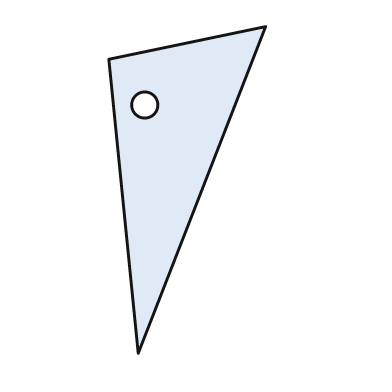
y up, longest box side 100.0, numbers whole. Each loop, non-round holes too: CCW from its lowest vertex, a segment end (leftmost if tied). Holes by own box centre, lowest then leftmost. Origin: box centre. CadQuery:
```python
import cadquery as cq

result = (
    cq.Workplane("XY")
    .moveTo(-15.0, -50.0)
    .lineTo(24.0, 50.0)
    .lineTo(-24.0, 40.0)
    .close()
    .moveTo(-13.0, 26.0)
    .circle(4.0)
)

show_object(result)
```